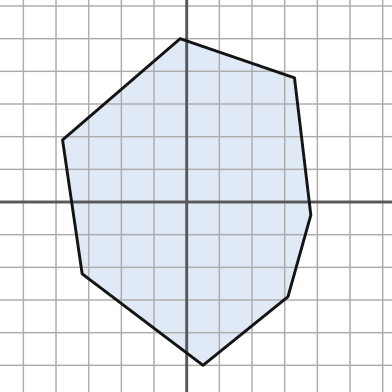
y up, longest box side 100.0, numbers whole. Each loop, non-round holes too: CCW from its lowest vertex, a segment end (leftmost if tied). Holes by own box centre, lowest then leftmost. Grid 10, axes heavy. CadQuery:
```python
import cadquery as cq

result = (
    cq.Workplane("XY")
    .moveTo(5.0, -50.0)
    .lineTo(31.0, -29.0)
    .lineTo(38.0, -4.0)
    .lineTo(33.0, 38.0)
    .lineTo(-2.0, 50.0)
    .lineTo(-38.0, 19.0)
    .lineTo(-32.0, -22.0)
    .close()
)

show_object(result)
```